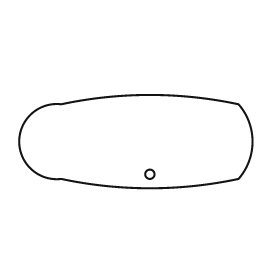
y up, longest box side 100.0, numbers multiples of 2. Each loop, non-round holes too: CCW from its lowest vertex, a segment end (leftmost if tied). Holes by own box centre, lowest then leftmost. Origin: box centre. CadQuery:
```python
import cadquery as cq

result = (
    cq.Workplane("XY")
    .moveTo(-32.0, -16.0)
    .threePointArc((6.0, -20.0), (44.0, -16.0))
    .threePointArc((50.0, 0.0), (44.0, 16.0))
    .threePointArc((6.0, 20.0), (-32.0, 16.0))
    .threePointArc((-50.0, 0.0), (-32.0, -16.0))
    .close()
    .moveTo(6.0, -14.0)
    .circle(2.0)
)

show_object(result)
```